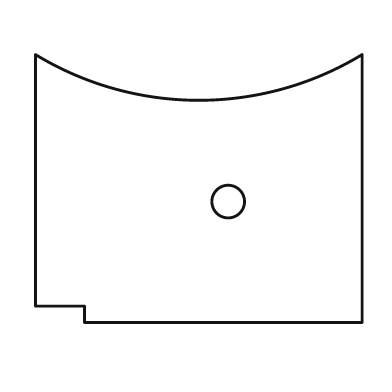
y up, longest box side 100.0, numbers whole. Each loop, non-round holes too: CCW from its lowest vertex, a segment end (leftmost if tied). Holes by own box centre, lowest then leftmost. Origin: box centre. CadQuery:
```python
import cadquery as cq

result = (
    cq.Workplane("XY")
    .moveTo(-35.0, -41.0)
    .lineTo(50.0, -41.0)
    .lineTo(50.0, 41.0)
    .threePointArc((0.0, 27.0), (-50.0, 41.0))
    .lineTo(-50.0, -36.0)
    .lineTo(-35.0, -36.0)
    .close()
    .moveTo(9.0, -4.0)
    .circle(5.0)
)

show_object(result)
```